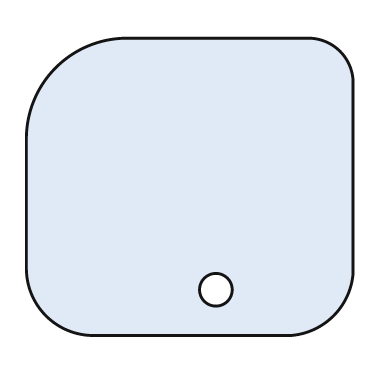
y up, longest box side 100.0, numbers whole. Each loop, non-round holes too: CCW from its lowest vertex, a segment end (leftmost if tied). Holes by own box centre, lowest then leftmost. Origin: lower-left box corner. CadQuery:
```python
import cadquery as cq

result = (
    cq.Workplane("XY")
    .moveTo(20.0, 0.0)
    .lineTo(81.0, 0.0)
    .threePointArc((94.0, 6.0), (100.0, 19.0))
    .lineTo(100.0, 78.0)
    .threePointArc((96.0, 87.0), (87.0, 91.0))
    .lineTo(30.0, 91.0)
    .threePointArc((9.0, 82.0), (0.0, 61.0))
    .lineTo(0.0, 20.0)
    .threePointArc((6.0, 6.0), (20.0, 0.0))
    .close()
    .moveTo(58.0, 14.0)
    .circle(5.0)
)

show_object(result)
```